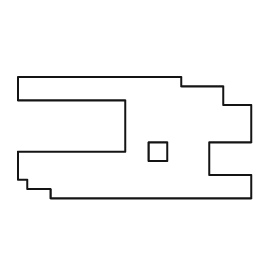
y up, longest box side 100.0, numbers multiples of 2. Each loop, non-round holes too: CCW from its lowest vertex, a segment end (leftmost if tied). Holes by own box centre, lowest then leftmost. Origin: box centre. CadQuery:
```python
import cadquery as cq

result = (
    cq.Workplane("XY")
    .moveTo(-36.0, -26.0)
    .lineTo(50.0, -26.0)
    .lineTo(50.0, -16.0)
    .lineTo(32.0, -16.0)
    .lineTo(32.0, -2.0)
    .lineTo(50.0, -2.0)
    .lineTo(50.0, 14.0)
    .lineTo(38.0, 14.0)
    .lineTo(38.0, 22.0)
    .lineTo(20.0, 22.0)
    .lineTo(20.0, 26.0)
    .lineTo(-50.0, 26.0)
    .lineTo(-50.0, 16.0)
    .lineTo(-4.0, 16.0)
    .lineTo(-4.0, -6.0)
    .lineTo(-50.0, -6.0)
    .lineTo(-50.0, -18.0)
    .lineTo(-46.0, -18.0)
    .lineTo(-46.0, -22.0)
    .lineTo(-36.0, -22.0)
    .close()
    .moveTo(6.0, -10.0)
    .lineTo(14.0, -10.0)
    .lineTo(14.0, -2.0)
    .lineTo(6.0, -2.0)
    .close()
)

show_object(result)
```